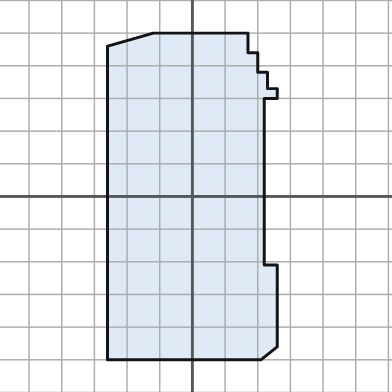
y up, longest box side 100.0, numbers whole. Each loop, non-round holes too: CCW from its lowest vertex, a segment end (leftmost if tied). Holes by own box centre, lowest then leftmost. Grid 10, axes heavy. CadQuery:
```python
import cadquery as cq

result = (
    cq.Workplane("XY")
    .moveTo(-26.0, -50.0)
    .lineTo(21.0, -50.0)
    .lineTo(26.0, -46.0)
    .lineTo(26.0, -21.0)
    .lineTo(22.0, -21.0)
    .lineTo(22.0, 30.0)
    .lineTo(26.0, 30.0)
    .lineTo(26.0, 33.0)
    .lineTo(23.0, 33.0)
    .lineTo(23.0, 38.0)
    .lineTo(20.0, 38.0)
    .lineTo(20.0, 44.0)
    .lineTo(17.0, 44.0)
    .lineTo(17.0, 50.0)
    .lineTo(-12.0, 50.0)
    .lineTo(-26.0, 46.0)
    .close()
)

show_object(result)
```